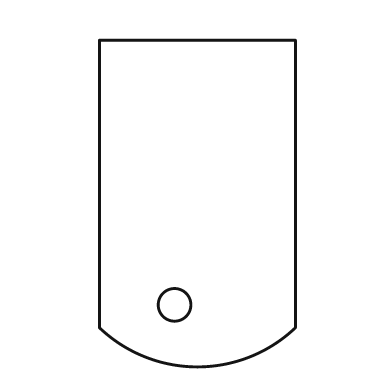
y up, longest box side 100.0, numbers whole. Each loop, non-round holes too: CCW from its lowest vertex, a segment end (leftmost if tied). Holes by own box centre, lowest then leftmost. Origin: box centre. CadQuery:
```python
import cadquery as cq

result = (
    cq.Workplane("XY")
    .moveTo(-30.0, -38.0)
    .threePointArc((0.0, -50.0), (30.0, -38.0))
    .lineTo(30.0, 50.0)
    .lineTo(-30.0, 50.0)
    .close()
    .moveTo(-7.0, -31.0)
    .circle(5.0)
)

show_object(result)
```